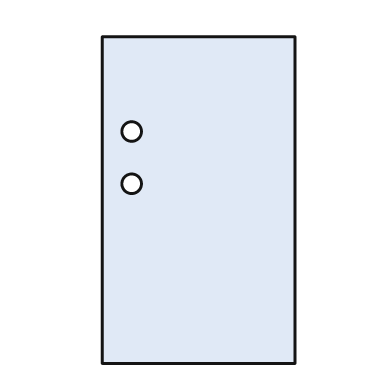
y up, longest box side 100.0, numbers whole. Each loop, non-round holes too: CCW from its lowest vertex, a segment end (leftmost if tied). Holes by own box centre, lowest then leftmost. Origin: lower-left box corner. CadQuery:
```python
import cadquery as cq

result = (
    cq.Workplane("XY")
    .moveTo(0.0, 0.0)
    .lineTo(59.0, 0.0)
    .lineTo(59.0, 100.0)
    .lineTo(0.0, 100.0)
    .close()
    .moveTo(9.0, 55.0)
    .circle(3.0)
    .moveTo(9.0, 71.0)
    .circle(3.0)
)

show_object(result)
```